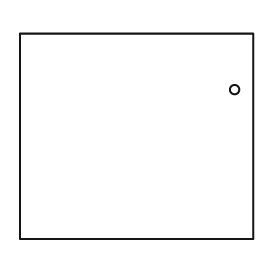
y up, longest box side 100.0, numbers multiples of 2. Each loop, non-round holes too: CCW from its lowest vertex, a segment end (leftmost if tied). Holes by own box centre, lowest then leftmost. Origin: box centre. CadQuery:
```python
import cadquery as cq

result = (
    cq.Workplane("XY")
    .moveTo(-50.0, -44.0)
    .lineTo(50.0, -44.0)
    .lineTo(50.0, 44.0)
    .lineTo(-50.0, 44.0)
    .close()
    .moveTo(42.0, 20.0)
    .circle(2.0)
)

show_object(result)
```